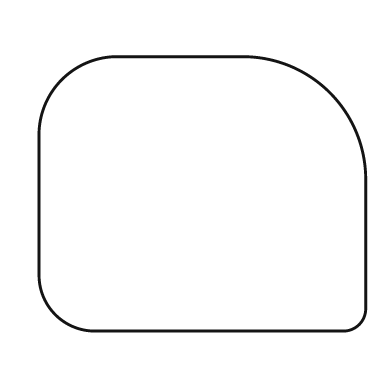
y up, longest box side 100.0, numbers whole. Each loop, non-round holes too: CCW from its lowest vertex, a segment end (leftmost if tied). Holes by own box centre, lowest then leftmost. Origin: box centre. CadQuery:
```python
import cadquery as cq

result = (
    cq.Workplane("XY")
    .moveTo(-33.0, -42.0)
    .lineTo(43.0, -42.0)
    .threePointArc((48.0, -40.0), (50.0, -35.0))
    .lineTo(50.0, 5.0)
    .threePointArc((39.0, 31.0), (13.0, 42.0))
    .lineTo(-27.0, 42.0)
    .threePointArc((-43.0, 35.0), (-50.0, 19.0))
    .lineTo(-50.0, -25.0)
    .threePointArc((-45.0, -37.0), (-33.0, -42.0))
    .close()
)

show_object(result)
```